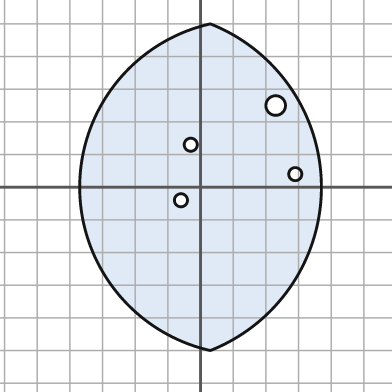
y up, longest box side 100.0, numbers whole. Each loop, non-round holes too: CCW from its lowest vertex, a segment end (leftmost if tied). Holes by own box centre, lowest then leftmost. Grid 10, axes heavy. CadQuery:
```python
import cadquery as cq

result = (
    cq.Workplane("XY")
    .moveTo(3.0, -50.0)
    .threePointArc((37.0, 0.0), (3.0, 50.0))
    .threePointArc((-37.0, 0.0), (3.0, -50.0))
    .close()
    .moveTo(-6.0, -4.0)
    .circle(2.0)
    .moveTo(29.0, 4.0)
    .circle(2.0)
    .moveTo(-3.0, 13.0)
    .circle(2.0)
    .moveTo(23.0, 25.0)
    .circle(3.0)
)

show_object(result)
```